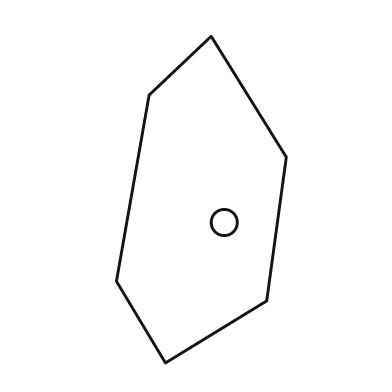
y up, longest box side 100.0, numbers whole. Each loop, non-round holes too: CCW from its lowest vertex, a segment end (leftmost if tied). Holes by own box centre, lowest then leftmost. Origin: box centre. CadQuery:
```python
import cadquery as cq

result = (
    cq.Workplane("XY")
    .moveTo(-11.0, -50.0)
    .lineTo(20.0, -31.0)
    .lineTo(26.0, 13.0)
    .lineTo(3.0, 50.0)
    .lineTo(-16.0, 32.0)
    .lineTo(-26.0, -25.0)
    .close()
    .moveTo(7.0, -7.0)
    .circle(4.0)
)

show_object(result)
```